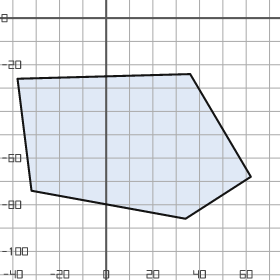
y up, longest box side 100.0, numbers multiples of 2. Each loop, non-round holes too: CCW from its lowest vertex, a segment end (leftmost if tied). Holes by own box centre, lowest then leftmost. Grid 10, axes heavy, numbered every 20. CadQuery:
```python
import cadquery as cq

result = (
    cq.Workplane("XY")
    .moveTo(34.0, -86.0)
    .lineTo(62.0, -68.0)
    .lineTo(36.0, -24.0)
    .lineTo(-38.0, -26.0)
    .lineTo(-32.0, -74.0)
    .close()
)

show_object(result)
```